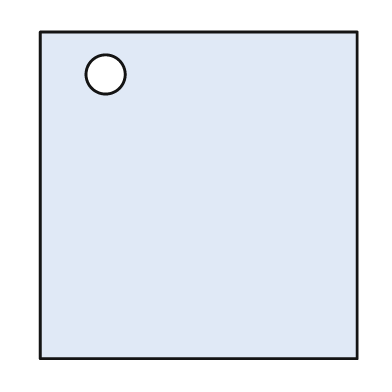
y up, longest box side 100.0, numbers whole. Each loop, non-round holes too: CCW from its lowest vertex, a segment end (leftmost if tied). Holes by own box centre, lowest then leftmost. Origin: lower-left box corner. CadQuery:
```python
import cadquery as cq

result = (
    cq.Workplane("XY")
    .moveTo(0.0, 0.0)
    .lineTo(97.0, 0.0)
    .lineTo(97.0, 100.0)
    .lineTo(0.0, 100.0)
    .close()
    .moveTo(20.0, 87.0)
    .circle(6.0)
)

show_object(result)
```